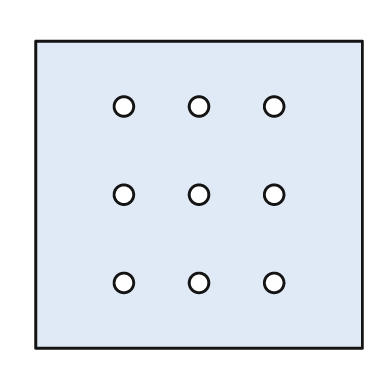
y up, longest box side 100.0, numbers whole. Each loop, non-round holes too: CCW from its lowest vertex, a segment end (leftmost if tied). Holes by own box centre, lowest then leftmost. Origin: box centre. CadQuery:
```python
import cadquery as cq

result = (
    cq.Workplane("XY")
    .moveTo(-50.0, -47.0)
    .lineTo(50.0, -47.0)
    .lineTo(50.0, 47.0)
    .lineTo(-50.0, 47.0)
    .close()
    .moveTo(-23.0, -27.0)
    .circle(3.0)
    .moveTo(0.0, -27.0)
    .circle(3.0)
    .moveTo(23.0, -27.0)
    .circle(3.0)
    .moveTo(-23.0, 0.0)
    .circle(3.0)
    .moveTo(0.0, 0.0)
    .circle(3.0)
    .moveTo(23.0, 0.0)
    .circle(3.0)
    .moveTo(-23.0, 27.0)
    .circle(3.0)
    .moveTo(0.0, 27.0)
    .circle(3.0)
    .moveTo(23.0, 27.0)
    .circle(3.0)
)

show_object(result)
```